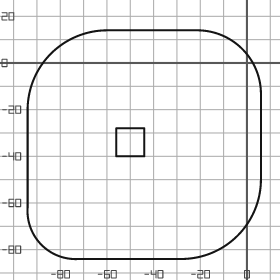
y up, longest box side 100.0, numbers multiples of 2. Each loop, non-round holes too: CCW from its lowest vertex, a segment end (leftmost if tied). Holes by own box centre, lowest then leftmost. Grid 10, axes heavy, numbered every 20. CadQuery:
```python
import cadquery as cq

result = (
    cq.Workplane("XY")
    .moveTo(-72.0, -84.0)
    .lineTo(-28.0, -84.0)
    .threePointArc((-4.0, -74.0), (6.0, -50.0))
    .lineTo(6.0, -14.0)
    .threePointArc((-2.0, 6.0), (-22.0, 14.0))
    .lineTo(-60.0, 14.0)
    .threePointArc((-84.0, 4.0), (-94.0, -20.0))
    .lineTo(-94.0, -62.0)
    .threePointArc((-88.0, -78.0), (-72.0, -84.0))
    .close()
    .moveTo(-56.0, -40.0)
    .lineTo(-44.0, -40.0)
    .lineTo(-44.0, -28.0)
    .lineTo(-56.0, -28.0)
    .close()
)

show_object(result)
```